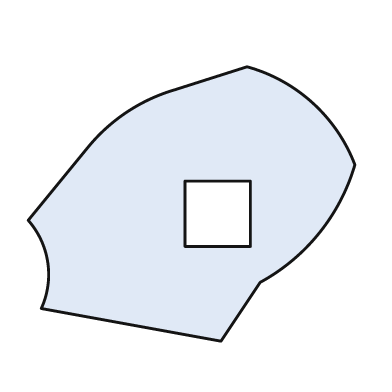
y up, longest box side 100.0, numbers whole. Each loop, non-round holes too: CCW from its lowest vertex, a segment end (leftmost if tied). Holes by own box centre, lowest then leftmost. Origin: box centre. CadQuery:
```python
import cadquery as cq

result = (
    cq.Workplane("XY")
    .moveTo(9.0, -42.0)
    .lineTo(21.0, -24.0)
    .threePointArc((39.0, -9.0), (50.0, 12.0))
    .threePointArc((37.0, 31.0), (17.0, 42.0))
    .lineTo(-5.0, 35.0)
    .threePointArc((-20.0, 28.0), (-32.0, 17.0))
    .lineTo(-50.0, -5.0)
    .threePointArc((-44.0, -18.0), (-46.0, -32.0))
    .close()
    .moveTo(-2.0, -13.0)
    .lineTo(18.0, -13.0)
    .lineTo(18.0, 7.0)
    .lineTo(-2.0, 7.0)
    .close()
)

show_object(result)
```